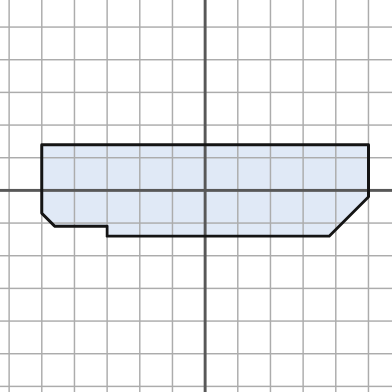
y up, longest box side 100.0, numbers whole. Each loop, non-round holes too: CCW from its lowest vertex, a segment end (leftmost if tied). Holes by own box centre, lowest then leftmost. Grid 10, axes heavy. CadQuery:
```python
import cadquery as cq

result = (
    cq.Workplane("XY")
    .moveTo(-30.0, -14.0)
    .lineTo(38.0, -14.0)
    .lineTo(50.0, -2.0)
    .lineTo(50.0, 14.0)
    .lineTo(-50.0, 14.0)
    .lineTo(-50.0, -7.0)
    .lineTo(-46.0, -11.0)
    .lineTo(-30.0, -11.0)
    .close()
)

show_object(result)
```